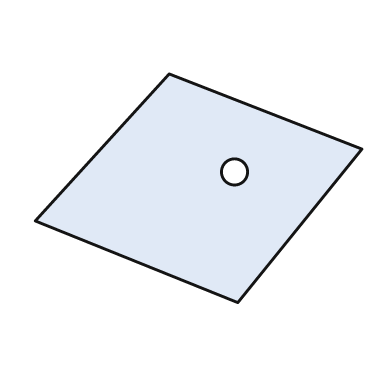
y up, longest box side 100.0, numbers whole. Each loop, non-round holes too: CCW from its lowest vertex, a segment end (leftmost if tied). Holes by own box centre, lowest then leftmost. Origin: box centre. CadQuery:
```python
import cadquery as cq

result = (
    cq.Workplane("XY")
    .moveTo(12.0, -35.0)
    .lineTo(50.0, 12.0)
    .lineTo(-9.0, 35.0)
    .lineTo(-50.0, -10.0)
    .close()
    .moveTo(11.0, 5.0)
    .circle(4.0)
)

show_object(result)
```